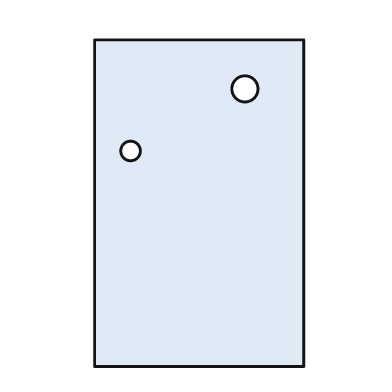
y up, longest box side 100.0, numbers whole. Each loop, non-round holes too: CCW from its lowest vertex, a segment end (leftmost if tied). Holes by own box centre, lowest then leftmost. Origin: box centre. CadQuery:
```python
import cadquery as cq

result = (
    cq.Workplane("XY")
    .moveTo(-32.0, -50.0)
    .lineTo(32.0, -50.0)
    .lineTo(32.0, 50.0)
    .lineTo(-32.0, 50.0)
    .close()
    .moveTo(-21.0, 16.0)
    .circle(3.0)
    .moveTo(14.0, 35.0)
    .circle(4.0)
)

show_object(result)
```